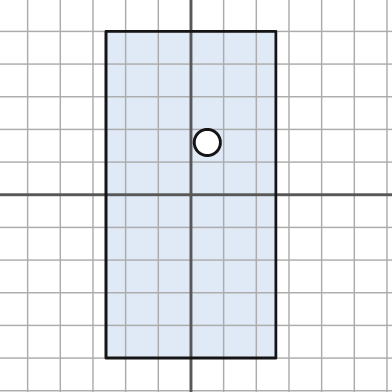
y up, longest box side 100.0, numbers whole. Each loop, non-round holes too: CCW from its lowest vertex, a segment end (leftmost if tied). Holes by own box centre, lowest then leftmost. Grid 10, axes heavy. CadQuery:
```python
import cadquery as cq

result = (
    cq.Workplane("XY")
    .moveTo(-26.0, -50.0)
    .lineTo(26.0, -50.0)
    .lineTo(26.0, 50.0)
    .lineTo(-26.0, 50.0)
    .close()
    .moveTo(5.0, 16.0)
    .circle(4.0)
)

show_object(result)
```